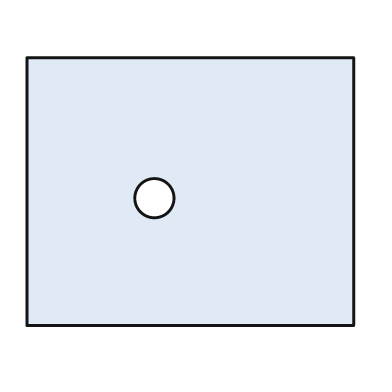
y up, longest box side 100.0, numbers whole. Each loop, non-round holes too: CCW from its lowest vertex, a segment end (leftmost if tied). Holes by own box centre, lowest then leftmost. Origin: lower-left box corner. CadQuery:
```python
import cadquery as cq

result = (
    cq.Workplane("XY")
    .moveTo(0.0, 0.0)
    .lineTo(100.0, 0.0)
    .lineTo(100.0, 82.0)
    .lineTo(0.0, 82.0)
    .close()
    .moveTo(39.0, 39.0)
    .circle(6.0)
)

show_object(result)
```